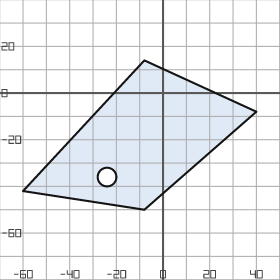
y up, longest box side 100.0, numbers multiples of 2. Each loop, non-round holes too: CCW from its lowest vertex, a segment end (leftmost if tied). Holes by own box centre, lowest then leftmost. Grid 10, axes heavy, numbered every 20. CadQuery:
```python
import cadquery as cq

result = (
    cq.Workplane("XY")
    .moveTo(-8.0, -50.0)
    .lineTo(40.0, -8.0)
    .lineTo(-8.0, 14.0)
    .lineTo(-60.0, -42.0)
    .close()
    .moveTo(-24.0, -36.0)
    .circle(4.0)
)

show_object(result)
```